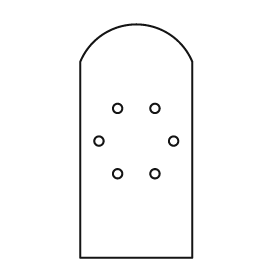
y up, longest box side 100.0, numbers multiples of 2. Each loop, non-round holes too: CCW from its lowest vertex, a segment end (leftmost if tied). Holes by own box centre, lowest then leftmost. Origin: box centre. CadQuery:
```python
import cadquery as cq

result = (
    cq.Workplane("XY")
    .moveTo(-24.0, -50.0)
    .lineTo(24.0, -50.0)
    .lineTo(24.0, 34.0)
    .threePointArc((0.0, 50.0), (-24.0, 34.0))
    .close()
    .moveTo(-8.0, -14.0)
    .circle(2.0)
    .moveTo(8.0, -14.0)
    .circle(2.0)
    .moveTo(-16.0, 0.0)
    .circle(2.0)
    .moveTo(16.0, 0.0)
    .circle(2.0)
    .moveTo(-8.0, 14.0)
    .circle(2.0)
    .moveTo(8.0, 14.0)
    .circle(2.0)
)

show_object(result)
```